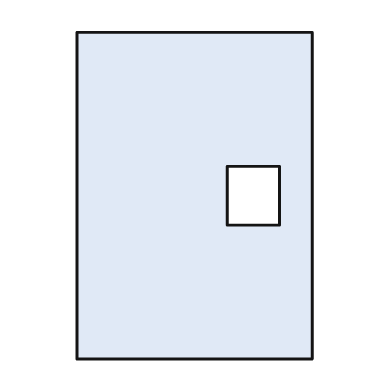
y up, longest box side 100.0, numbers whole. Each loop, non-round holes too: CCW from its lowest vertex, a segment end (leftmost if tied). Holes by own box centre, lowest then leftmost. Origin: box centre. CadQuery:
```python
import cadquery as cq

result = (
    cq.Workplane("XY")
    .moveTo(-36.0, -50.0)
    .lineTo(36.0, -50.0)
    .lineTo(36.0, 50.0)
    .lineTo(-36.0, 50.0)
    .close()
    .moveTo(10.0, -9.0)
    .lineTo(26.0, -9.0)
    .lineTo(26.0, 9.0)
    .lineTo(10.0, 9.0)
    .close()
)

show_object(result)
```